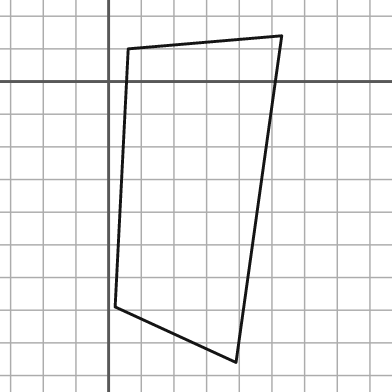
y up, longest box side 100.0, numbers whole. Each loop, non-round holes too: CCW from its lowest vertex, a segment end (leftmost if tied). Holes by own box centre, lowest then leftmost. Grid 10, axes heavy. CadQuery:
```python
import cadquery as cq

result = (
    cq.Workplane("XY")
    .moveTo(39.0, -86.0)
    .lineTo(53.0, 14.0)
    .lineTo(6.0, 10.0)
    .lineTo(2.0, -69.0)
    .close()
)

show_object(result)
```